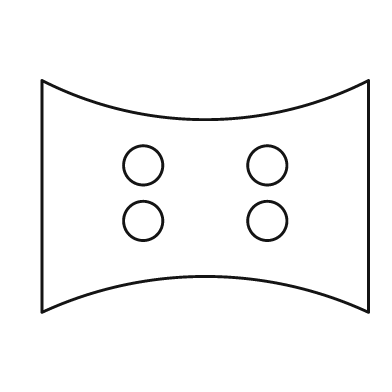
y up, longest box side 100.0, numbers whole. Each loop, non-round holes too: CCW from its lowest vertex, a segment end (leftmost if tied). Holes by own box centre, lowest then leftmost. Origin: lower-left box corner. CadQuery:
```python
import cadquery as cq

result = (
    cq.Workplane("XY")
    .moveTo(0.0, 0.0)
    .threePointArc((50.0, 11.0), (100.0, 0.0))
    .lineTo(100.0, 71.0)
    .threePointArc((50.0, 59.0), (0.0, 71.0))
    .close()
    .moveTo(31.0, 28.0)
    .circle(6.0)
    .moveTo(69.0, 28.0)
    .circle(6.0)
    .moveTo(31.0, 45.0)
    .circle(6.0)
    .moveTo(69.0, 45.0)
    .circle(6.0)
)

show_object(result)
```